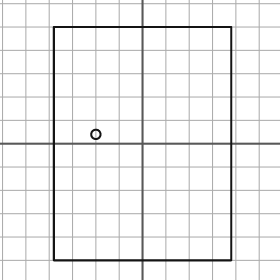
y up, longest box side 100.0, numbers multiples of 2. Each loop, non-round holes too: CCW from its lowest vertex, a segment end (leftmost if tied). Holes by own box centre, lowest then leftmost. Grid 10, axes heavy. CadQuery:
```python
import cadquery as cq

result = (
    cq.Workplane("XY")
    .moveTo(-38.0, -50.0)
    .lineTo(38.0, -50.0)
    .lineTo(38.0, 50.0)
    .lineTo(-38.0, 50.0)
    .close()
    .moveTo(-20.0, 4.0)
    .circle(2.0)
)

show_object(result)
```